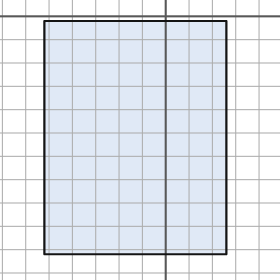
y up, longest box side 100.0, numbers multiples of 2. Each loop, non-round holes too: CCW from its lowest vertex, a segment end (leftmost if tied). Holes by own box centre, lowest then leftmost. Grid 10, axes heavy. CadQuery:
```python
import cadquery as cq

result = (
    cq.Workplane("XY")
    .moveTo(-52.0, -102.0)
    .lineTo(26.0, -102.0)
    .lineTo(26.0, -2.0)
    .lineTo(-52.0, -2.0)
    .close()
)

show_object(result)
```